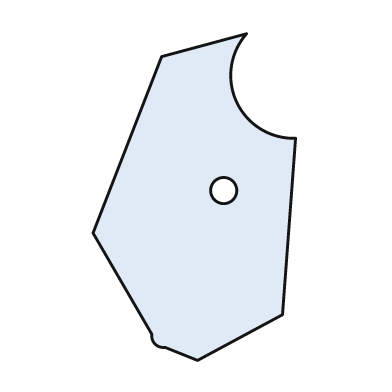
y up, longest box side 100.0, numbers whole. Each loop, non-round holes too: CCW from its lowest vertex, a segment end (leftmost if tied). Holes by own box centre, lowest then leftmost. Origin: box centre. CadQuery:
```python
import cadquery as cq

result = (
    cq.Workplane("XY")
    .moveTo(1.0, -50.0)
    .lineTo(27.0, -36.0)
    .lineTo(31.0, 18.0)
    .threePointArc((13.0, 29.0), (16.0, 50.0))
    .lineTo(-10.0, 43.0)
    .lineTo(-31.0, -11.0)
    .lineTo(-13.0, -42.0)
    .threePointArc((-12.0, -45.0), (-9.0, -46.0))
    .close()
    .moveTo(9.0, 2.0)
    .circle(4.0)
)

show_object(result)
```